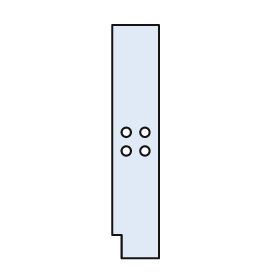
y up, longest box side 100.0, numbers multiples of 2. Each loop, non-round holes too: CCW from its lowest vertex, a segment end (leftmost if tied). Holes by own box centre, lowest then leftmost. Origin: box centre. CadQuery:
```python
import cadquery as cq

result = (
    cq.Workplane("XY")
    .moveTo(-6.0, -50.0)
    .lineTo(10.0, -50.0)
    .lineTo(10.0, 50.0)
    .lineTo(-10.0, 50.0)
    .lineTo(-10.0, -40.0)
    .lineTo(-6.0, -40.0)
    .close()
    .moveTo(-4.0, -4.0)
    .circle(2.0)
    .moveTo(4.0, -4.0)
    .circle(2.0)
    .moveTo(-4.0, 4.0)
    .circle(2.0)
    .moveTo(4.0, 4.0)
    .circle(2.0)
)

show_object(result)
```